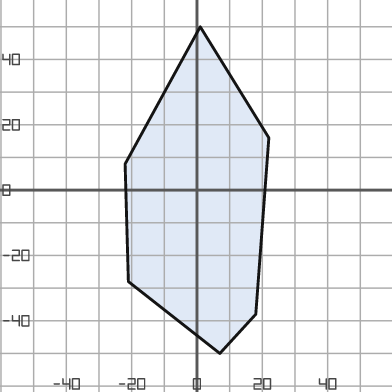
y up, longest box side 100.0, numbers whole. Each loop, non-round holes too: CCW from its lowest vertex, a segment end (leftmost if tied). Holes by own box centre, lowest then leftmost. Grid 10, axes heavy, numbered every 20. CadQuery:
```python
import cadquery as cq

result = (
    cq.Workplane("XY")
    .moveTo(7.0, -50.0)
    .lineTo(18.0, -38.0)
    .lineTo(22.0, 16.0)
    .lineTo(1.0, 50.0)
    .lineTo(-22.0, 8.0)
    .lineTo(-21.0, -28.0)
    .close()
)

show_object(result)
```